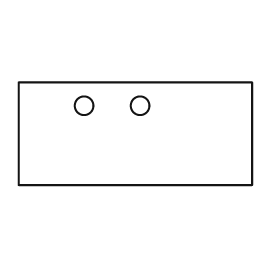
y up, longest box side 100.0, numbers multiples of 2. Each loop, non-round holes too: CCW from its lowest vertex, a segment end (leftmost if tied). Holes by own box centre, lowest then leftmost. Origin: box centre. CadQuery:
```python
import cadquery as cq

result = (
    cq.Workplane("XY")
    .moveTo(-50.0, -22.0)
    .lineTo(50.0, -22.0)
    .lineTo(50.0, 22.0)
    .lineTo(-50.0, 22.0)
    .close()
    .moveTo(-22.0, 12.0)
    .circle(4.0)
    .moveTo(2.0, 12.0)
    .circle(4.0)
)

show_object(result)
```